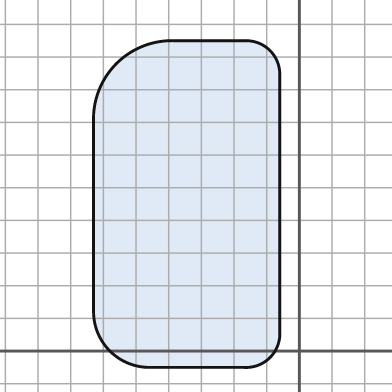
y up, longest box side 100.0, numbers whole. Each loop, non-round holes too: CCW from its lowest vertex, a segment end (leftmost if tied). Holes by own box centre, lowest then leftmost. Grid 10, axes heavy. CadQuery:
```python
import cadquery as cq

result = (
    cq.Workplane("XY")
    .moveTo(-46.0, -5.0)
    .lineTo(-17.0, -5.0)
    .threePointArc((-9.0, -2.0), (-6.0, 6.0))
    .lineTo(-6.0, 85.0)
    .threePointArc((-9.0, 92.0), (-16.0, 95.0))
    .lineTo(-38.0, 95.0)
    .threePointArc((-56.0, 88.0), (-63.0, 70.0))
    .lineTo(-63.0, 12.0)
    .threePointArc((-58.0, 0.0), (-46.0, -5.0))
    .close()
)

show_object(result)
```